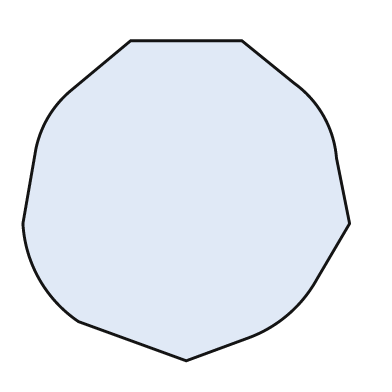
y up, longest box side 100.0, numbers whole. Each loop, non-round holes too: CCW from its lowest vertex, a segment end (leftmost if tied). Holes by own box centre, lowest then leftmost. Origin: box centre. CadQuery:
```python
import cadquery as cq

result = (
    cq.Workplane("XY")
    .moveTo(0.0, -49.0)
    .lineTo(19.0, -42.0)
    .threePointArc((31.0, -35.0), (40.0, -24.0))
    .lineTo(50.0, -7.0)
    .lineTo(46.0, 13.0)
    .threePointArc((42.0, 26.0), (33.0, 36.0))
    .lineTo(17.0, 49.0)
    .lineTo(-17.0, 49.0)
    .lineTo(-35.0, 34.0)
    .threePointArc((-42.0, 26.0), (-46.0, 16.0))
    .lineTo(-50.0, -7.0)
    .threePointArc((-45.0, -24.0), (-33.0, -37.0))
    .close()
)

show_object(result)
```